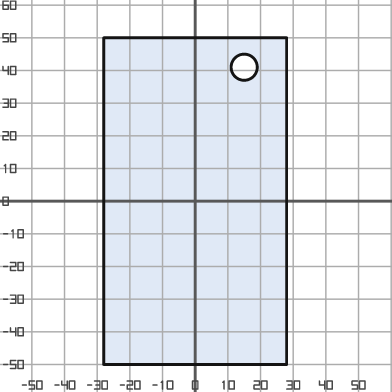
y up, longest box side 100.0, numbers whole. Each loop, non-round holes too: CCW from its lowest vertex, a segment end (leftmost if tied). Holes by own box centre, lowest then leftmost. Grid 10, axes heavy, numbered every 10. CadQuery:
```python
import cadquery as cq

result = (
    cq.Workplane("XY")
    .moveTo(-28.0, -50.0)
    .lineTo(28.0, -50.0)
    .lineTo(28.0, 50.0)
    .lineTo(-28.0, 50.0)
    .close()
    .moveTo(15.0, 41.0)
    .circle(4.0)
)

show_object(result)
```